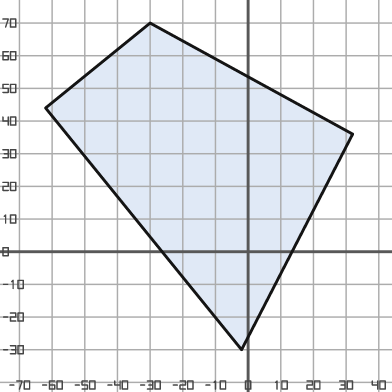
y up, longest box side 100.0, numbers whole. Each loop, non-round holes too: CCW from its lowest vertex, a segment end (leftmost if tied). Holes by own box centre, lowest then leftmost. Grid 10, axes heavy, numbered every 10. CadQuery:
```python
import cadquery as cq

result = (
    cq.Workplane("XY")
    .moveTo(-2.0, -30.0)
    .lineTo(32.0, 36.0)
    .lineTo(-30.0, 70.0)
    .lineTo(-62.0, 44.0)
    .close()
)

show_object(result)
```